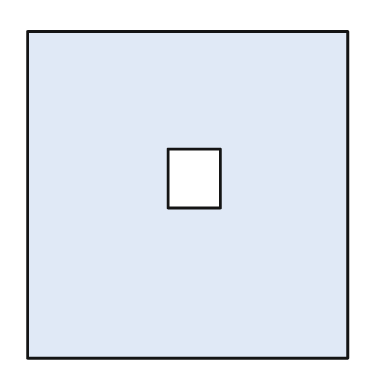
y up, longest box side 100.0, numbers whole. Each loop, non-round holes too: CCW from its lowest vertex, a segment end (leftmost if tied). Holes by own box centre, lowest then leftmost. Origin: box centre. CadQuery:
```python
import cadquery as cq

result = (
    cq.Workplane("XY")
    .moveTo(-49.0, -50.0)
    .lineTo(49.0, -50.0)
    .lineTo(49.0, 50.0)
    .lineTo(-49.0, 50.0)
    .close()
    .moveTo(-6.0, -4.0)
    .lineTo(10.0, -4.0)
    .lineTo(10.0, 14.0)
    .lineTo(-6.0, 14.0)
    .close()
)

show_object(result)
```